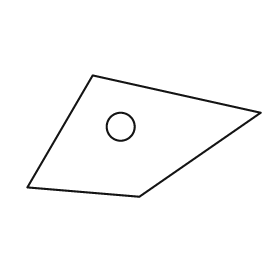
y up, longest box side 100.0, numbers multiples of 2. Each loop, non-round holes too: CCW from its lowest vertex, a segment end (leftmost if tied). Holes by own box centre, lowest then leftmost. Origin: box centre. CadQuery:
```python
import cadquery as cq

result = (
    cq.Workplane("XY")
    .moveTo(-2.0, -26.0)
    .lineTo(50.0, 10.0)
    .lineTo(-22.0, 26.0)
    .lineTo(-50.0, -22.0)
    .close()
    .moveTo(-10.0, 4.0)
    .circle(6.0)
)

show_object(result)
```